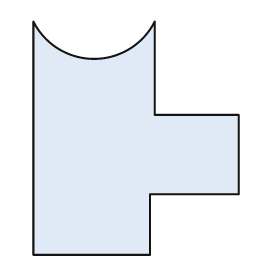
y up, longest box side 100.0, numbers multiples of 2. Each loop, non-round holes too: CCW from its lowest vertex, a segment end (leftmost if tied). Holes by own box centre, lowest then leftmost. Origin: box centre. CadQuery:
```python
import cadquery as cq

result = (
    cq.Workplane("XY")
    .moveTo(-44.0, -50.0)
    .lineTo(6.0, -50.0)
    .lineTo(6.0, -24.0)
    .lineTo(44.0, -24.0)
    .lineTo(44.0, 10.0)
    .lineTo(8.0, 10.0)
    .lineTo(8.0, 50.0)
    .threePointArc((-18.0, 34.0), (-44.0, 50.0))
    .close()
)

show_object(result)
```